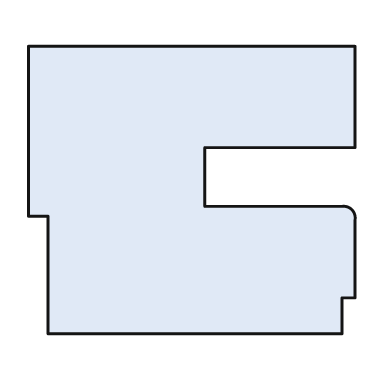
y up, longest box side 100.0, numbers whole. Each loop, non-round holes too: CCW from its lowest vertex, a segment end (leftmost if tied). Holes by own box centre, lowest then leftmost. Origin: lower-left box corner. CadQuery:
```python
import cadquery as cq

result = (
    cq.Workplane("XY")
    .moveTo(6.0, 0.0)
    .lineTo(96.0, 0.0)
    .lineTo(96.0, 11.0)
    .lineTo(100.0, 11.0)
    .lineTo(100.0, 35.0)
    .threePointArc((99.0, 38.0), (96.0, 39.0))
    .lineTo(54.0, 39.0)
    .lineTo(54.0, 57.0)
    .lineTo(100.0, 57.0)
    .lineTo(100.0, 88.0)
    .lineTo(0.0, 88.0)
    .lineTo(0.0, 36.0)
    .lineTo(6.0, 36.0)
    .close()
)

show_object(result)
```